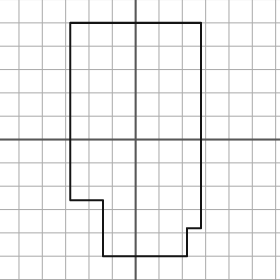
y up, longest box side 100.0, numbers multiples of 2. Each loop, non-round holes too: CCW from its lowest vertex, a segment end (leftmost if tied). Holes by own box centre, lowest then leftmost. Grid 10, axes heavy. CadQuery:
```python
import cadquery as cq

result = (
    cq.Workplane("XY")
    .moveTo(-14.0, -50.0)
    .lineTo(22.0, -50.0)
    .lineTo(22.0, -38.0)
    .lineTo(28.0, -38.0)
    .lineTo(28.0, 50.0)
    .lineTo(-28.0, 50.0)
    .lineTo(-28.0, -26.0)
    .lineTo(-14.0, -26.0)
    .close()
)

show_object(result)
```